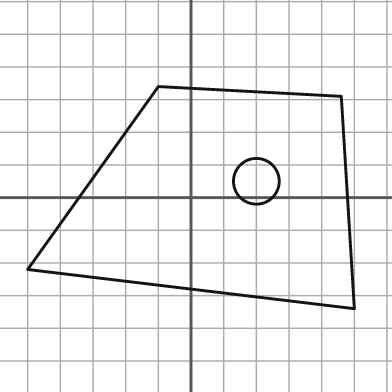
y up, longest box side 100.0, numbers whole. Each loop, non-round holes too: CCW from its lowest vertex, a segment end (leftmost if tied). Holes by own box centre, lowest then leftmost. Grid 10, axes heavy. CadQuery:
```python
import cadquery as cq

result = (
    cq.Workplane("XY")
    .moveTo(50.0, -34.0)
    .lineTo(46.0, 31.0)
    .lineTo(-10.0, 34.0)
    .lineTo(-50.0, -22.0)
    .close()
    .moveTo(20.0, 5.0)
    .circle(7.0)
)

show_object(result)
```